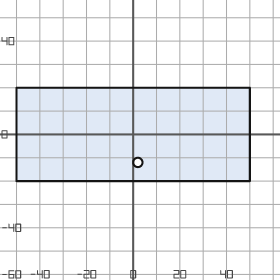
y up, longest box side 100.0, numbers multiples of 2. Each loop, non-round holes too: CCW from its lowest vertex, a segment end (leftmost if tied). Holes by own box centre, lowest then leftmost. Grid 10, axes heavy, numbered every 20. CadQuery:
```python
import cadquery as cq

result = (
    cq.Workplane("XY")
    .moveTo(-50.0, -20.0)
    .lineTo(50.0, -20.0)
    .lineTo(50.0, 20.0)
    .lineTo(-50.0, 20.0)
    .close()
    .moveTo(2.0, -12.0)
    .circle(2.0)
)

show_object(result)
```